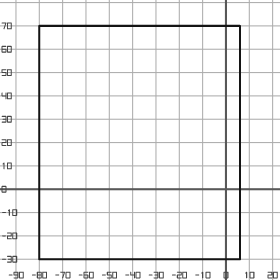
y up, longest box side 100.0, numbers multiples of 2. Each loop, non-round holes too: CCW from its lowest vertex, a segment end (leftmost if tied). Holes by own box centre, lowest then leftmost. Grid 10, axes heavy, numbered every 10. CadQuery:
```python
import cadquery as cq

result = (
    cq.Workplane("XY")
    .moveTo(-80.0, -30.0)
    .lineTo(6.0, -30.0)
    .lineTo(6.0, 70.0)
    .lineTo(-80.0, 70.0)
    .close()
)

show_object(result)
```